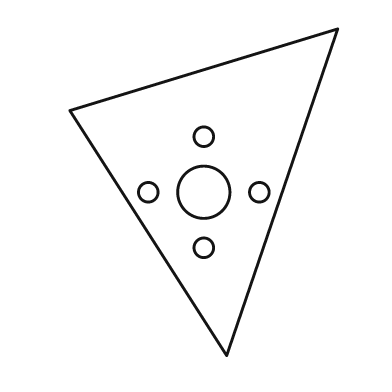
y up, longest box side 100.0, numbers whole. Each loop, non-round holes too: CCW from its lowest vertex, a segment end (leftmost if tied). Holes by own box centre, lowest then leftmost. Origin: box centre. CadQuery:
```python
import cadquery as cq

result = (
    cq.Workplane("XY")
    .moveTo(7.0, -50.0)
    .lineTo(41.0, 50.0)
    .lineTo(-41.0, 25.0)
    .close()
    .moveTo(0.0, -17.0)
    .circle(3.0)
    .moveTo(-17.0, 0.0)
    .circle(3.0)
    .moveTo(0.0, 0.0)
    .circle(8.0)
    .moveTo(17.0, 0.0)
    .circle(3.0)
    .moveTo(0.0, 17.0)
    .circle(3.0)
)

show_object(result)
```